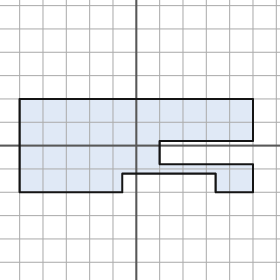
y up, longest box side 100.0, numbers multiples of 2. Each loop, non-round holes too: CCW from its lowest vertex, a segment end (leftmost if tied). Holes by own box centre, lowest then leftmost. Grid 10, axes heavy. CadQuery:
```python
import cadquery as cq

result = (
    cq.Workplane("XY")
    .moveTo(-50.0, -20.0)
    .lineTo(-6.0, -20.0)
    .lineTo(-6.0, -12.0)
    .lineTo(34.0, -12.0)
    .lineTo(34.0, -20.0)
    .lineTo(50.0, -20.0)
    .lineTo(50.0, -8.0)
    .lineTo(10.0, -8.0)
    .lineTo(10.0, 2.0)
    .lineTo(50.0, 2.0)
    .lineTo(50.0, 20.0)
    .lineTo(-50.0, 20.0)
    .close()
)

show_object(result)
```